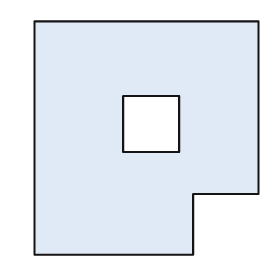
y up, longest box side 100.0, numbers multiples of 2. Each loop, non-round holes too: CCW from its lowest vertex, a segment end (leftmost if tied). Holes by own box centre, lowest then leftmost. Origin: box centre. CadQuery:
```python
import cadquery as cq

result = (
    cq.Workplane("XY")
    .moveTo(-48.0, -50.0)
    .lineTo(20.0, -50.0)
    .lineTo(20.0, -24.0)
    .lineTo(48.0, -24.0)
    .lineTo(48.0, 50.0)
    .lineTo(-48.0, 50.0)
    .close()
    .moveTo(-10.0, -6.0)
    .lineTo(14.0, -6.0)
    .lineTo(14.0, 18.0)
    .lineTo(-10.0, 18.0)
    .close()
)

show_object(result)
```